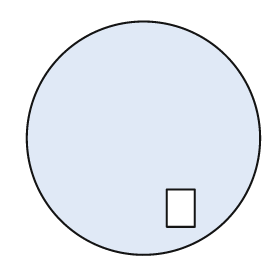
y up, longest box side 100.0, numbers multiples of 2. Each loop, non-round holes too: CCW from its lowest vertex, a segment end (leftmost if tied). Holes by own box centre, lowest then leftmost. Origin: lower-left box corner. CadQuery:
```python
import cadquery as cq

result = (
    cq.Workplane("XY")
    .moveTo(50.0, 50.0)
    .circle(50.0)
    .moveTo(60.0, 12.0)
    .lineTo(72.0, 12.0)
    .lineTo(72.0, 28.0)
    .lineTo(60.0, 28.0)
    .close()
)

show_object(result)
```